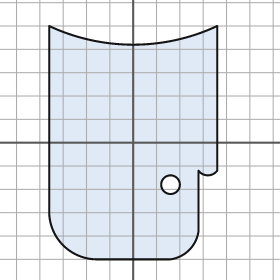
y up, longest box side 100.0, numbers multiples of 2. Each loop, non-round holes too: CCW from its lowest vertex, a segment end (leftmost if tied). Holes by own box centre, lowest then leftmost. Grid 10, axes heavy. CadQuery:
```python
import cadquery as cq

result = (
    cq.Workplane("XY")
    .moveTo(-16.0, -50.0)
    .lineTo(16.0, -50.0)
    .threePointArc((24.0, -46.0), (28.0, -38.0))
    .lineTo(28.0, -12.0)
    .threePointArc((32.0, -14.0), (36.0, -12.0))
    .lineTo(36.0, 50.0)
    .threePointArc((0.0, 42.0), (-36.0, 50.0))
    .lineTo(-36.0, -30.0)
    .threePointArc((-30.0, -44.0), (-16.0, -50.0))
    .close()
    .moveTo(16.0, -18.0)
    .circle(4.0)
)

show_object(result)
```